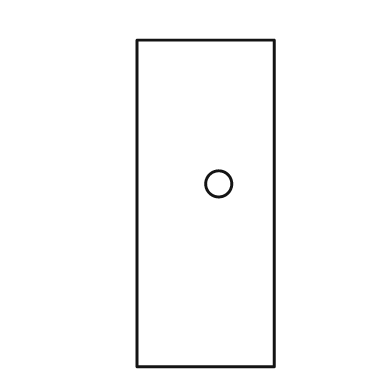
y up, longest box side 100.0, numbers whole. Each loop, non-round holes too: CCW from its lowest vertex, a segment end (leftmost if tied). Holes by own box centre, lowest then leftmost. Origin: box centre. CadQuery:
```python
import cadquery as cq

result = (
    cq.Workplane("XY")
    .moveTo(-21.0, -50.0)
    .lineTo(21.0, -50.0)
    .lineTo(21.0, 50.0)
    .lineTo(-21.0, 50.0)
    .close()
    .moveTo(4.0, 6.0)
    .circle(4.0)
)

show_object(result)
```